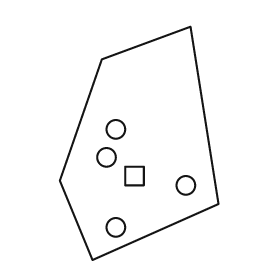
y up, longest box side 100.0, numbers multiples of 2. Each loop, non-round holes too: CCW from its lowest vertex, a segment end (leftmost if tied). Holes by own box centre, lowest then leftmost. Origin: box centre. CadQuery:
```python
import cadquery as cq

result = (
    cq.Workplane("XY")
    .moveTo(-20.0, -50.0)
    .lineTo(34.0, -26.0)
    .lineTo(22.0, 50.0)
    .lineTo(-16.0, 36.0)
    .lineTo(-34.0, -16.0)
    .close()
    .moveTo(-10.0, -36.0)
    .circle(4.0)
    .moveTo(20.0, -18.0)
    .circle(4.0)
    .moveTo(-6.0, -18.0)
    .lineTo(2.0, -18.0)
    .lineTo(2.0, -10.0)
    .lineTo(-6.0, -10.0)
    .close()
    .moveTo(-14.0, -6.0)
    .circle(4.0)
    .moveTo(-10.0, 6.0)
    .circle(4.0)
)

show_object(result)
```